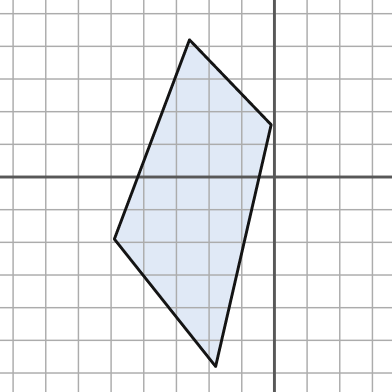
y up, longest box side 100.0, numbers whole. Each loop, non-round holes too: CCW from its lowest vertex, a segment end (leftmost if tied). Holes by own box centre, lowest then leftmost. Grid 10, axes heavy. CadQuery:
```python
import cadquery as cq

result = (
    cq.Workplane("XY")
    .moveTo(-18.0, -58.0)
    .lineTo(-1.0, 16.0)
    .lineTo(-26.0, 42.0)
    .lineTo(-49.0, -19.0)
    .close()
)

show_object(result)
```